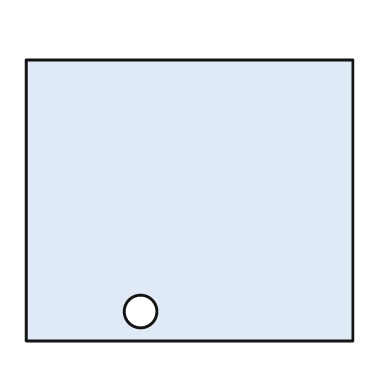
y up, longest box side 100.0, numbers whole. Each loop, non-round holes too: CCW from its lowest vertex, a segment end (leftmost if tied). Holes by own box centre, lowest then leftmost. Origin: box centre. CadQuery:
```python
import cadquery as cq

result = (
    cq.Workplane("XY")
    .moveTo(-50.0, -43.0)
    .lineTo(50.0, -43.0)
    .lineTo(50.0, 43.0)
    .lineTo(-50.0, 43.0)
    .close()
    .moveTo(-15.0, -34.0)
    .circle(5.0)
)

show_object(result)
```